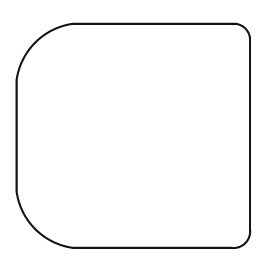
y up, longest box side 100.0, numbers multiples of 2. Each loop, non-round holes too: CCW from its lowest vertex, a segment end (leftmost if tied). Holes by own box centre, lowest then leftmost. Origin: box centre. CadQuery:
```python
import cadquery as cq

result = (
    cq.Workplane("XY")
    .moveTo(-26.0, -48.0)
    .lineTo(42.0, -48.0)
    .threePointArc((48.0, -46.0), (50.0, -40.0))
    .lineTo(50.0, 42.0)
    .threePointArc((48.0, 46.0), (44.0, 48.0))
    .lineTo(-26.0, 48.0)
    .threePointArc((-42.0, 40.0), (-50.0, 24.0))
    .lineTo(-50.0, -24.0)
    .threePointArc((-42.0, -40.0), (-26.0, -48.0))
    .close()
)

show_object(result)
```